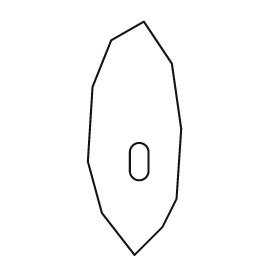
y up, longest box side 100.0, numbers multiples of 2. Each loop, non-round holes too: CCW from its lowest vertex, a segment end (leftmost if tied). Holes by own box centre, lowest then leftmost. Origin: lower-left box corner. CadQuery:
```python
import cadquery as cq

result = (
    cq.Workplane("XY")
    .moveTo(20.0, 0.0)
    .lineTo(32.0, 12.0)
    .lineTo(38.0, 24.0)
    .lineTo(40.0, 54.0)
    .lineTo(36.0, 82.0)
    .lineTo(24.0, 100.0)
    .lineTo(10.0, 92.0)
    .lineTo(2.0, 72.0)
    .lineTo(0.0, 40.0)
    .lineTo(6.0, 18.0)
    .close()
    .moveTo(18.0, 36.0)
    .threePointArc((22.0, 32.0), (26.0, 36.0))
    .lineTo(26.0, 44.0)
    .threePointArc((22.0, 48.0), (18.0, 44.0))
    .close()
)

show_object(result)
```